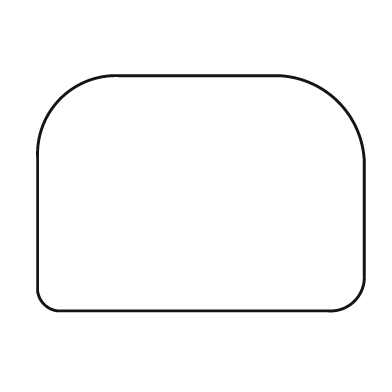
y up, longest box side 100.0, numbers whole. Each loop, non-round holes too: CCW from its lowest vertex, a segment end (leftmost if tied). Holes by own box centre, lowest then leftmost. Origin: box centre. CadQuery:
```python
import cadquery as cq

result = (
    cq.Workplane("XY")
    .moveTo(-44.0, -36.0)
    .lineTo(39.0, -36.0)
    .threePointArc((47.0, -33.0), (50.0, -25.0))
    .lineTo(50.0, 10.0)
    .threePointArc((42.0, 28.0), (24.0, 36.0))
    .lineTo(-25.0, 36.0)
    .threePointArc((-43.0, 29.0), (-50.0, 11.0))
    .lineTo(-50.0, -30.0)
    .threePointArc((-48.0, -34.0), (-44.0, -36.0))
    .close()
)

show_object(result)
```